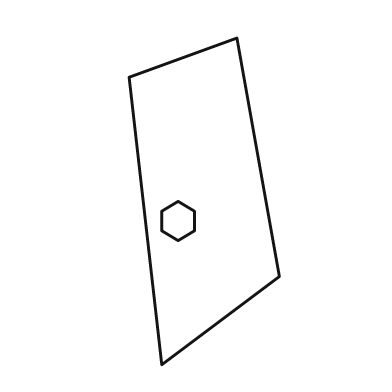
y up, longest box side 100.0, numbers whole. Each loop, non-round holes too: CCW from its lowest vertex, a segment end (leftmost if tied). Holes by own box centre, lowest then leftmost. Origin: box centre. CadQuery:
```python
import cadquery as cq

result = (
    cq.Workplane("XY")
    .moveTo(-13.0, -50.0)
    .lineTo(23.0, -23.0)
    .lineTo(10.0, 50.0)
    .lineTo(-23.0, 38.0)
    .close()
    .moveTo(-8.0, -12.0)
    .lineTo(-3.0, -9.0)
    .lineTo(-3.0, -3.0)
    .lineTo(-8.0, 0.0)
    .lineTo(-13.0, -3.0)
    .lineTo(-13.0, -9.0)
    .close()
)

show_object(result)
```